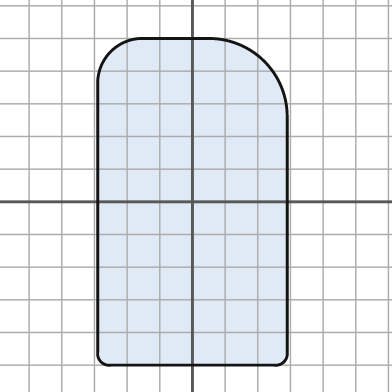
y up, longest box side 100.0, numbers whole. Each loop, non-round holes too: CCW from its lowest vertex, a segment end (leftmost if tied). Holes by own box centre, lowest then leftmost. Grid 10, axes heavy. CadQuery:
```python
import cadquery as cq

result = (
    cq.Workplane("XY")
    .moveTo(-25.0, -50.0)
    .lineTo(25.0, -50.0)
    .threePointArc((28.0, -49.0), (29.0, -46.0))
    .lineTo(29.0, 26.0)
    .threePointArc((22.0, 43.0), (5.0, 50.0))
    .lineTo(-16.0, 50.0)
    .threePointArc((-25.0, 46.0), (-29.0, 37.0))
    .lineTo(-29.0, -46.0)
    .threePointArc((-28.0, -49.0), (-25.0, -50.0))
    .close()
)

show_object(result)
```